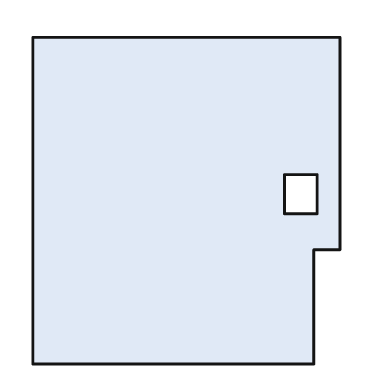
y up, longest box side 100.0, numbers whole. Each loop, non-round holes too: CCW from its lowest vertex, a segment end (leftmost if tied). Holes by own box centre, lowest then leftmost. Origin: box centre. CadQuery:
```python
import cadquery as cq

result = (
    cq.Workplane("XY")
    .moveTo(-47.0, -50.0)
    .lineTo(39.0, -50.0)
    .lineTo(39.0, -15.0)
    .lineTo(47.0, -15.0)
    .lineTo(47.0, 50.0)
    .lineTo(-47.0, 50.0)
    .close()
    .moveTo(30.0, -4.0)
    .lineTo(40.0, -4.0)
    .lineTo(40.0, 8.0)
    .lineTo(30.0, 8.0)
    .close()
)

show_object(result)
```